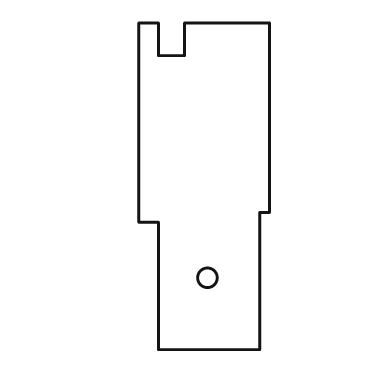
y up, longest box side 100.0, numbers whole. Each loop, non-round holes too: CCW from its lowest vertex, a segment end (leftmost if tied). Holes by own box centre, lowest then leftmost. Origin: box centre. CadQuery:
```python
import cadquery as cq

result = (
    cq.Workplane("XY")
    .moveTo(-14.0, -50.0)
    .lineTo(17.0, -50.0)
    .lineTo(17.0, -8.0)
    .lineTo(20.0, -8.0)
    .lineTo(20.0, 50.0)
    .lineTo(-6.0, 50.0)
    .lineTo(-6.0, 40.0)
    .lineTo(-14.0, 40.0)
    .lineTo(-14.0, 50.0)
    .lineTo(-20.0, 50.0)
    .lineTo(-20.0, -11.0)
    .lineTo(-14.0, -11.0)
    .close()
    .moveTo(1.0, -28.0)
    .circle(3.0)
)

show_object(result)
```